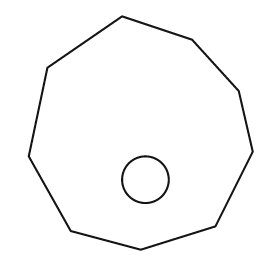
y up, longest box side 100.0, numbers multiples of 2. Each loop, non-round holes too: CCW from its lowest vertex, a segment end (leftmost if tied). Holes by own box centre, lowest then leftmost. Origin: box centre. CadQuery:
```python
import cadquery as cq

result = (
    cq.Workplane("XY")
    .moveTo(0.0, -50.0)
    .lineTo(32.0, -40.0)
    .lineTo(48.0, -8.0)
    .lineTo(42.0, 18.0)
    .lineTo(22.0, 40.0)
    .lineTo(-8.0, 50.0)
    .lineTo(-40.0, 28.0)
    .lineTo(-48.0, -10.0)
    .lineTo(-30.0, -42.0)
    .close()
    .moveTo(2.0, -20.0)
    .circle(10.0)
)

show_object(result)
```